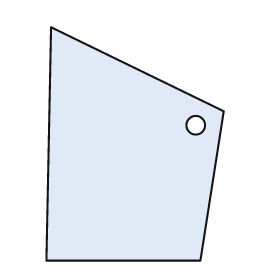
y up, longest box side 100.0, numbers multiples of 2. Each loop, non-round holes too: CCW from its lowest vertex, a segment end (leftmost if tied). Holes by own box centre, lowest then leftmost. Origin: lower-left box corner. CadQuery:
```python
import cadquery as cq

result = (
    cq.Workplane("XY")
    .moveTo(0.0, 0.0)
    .lineTo(66.0, 0.0)
    .lineTo(76.0, 64.0)
    .lineTo(2.0, 100.0)
    .close()
    .moveTo(64.0, 58.0)
    .circle(4.0)
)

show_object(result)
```